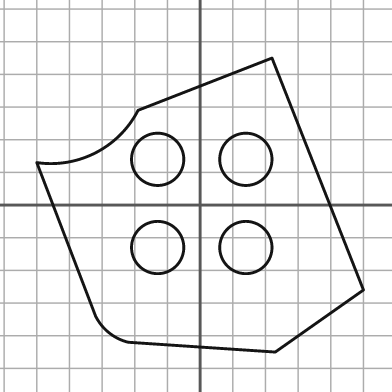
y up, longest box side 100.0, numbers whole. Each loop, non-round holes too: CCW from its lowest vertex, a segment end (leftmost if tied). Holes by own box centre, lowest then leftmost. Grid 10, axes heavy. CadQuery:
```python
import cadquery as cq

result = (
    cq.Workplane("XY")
    .moveTo(23.0, -45.0)
    .lineTo(50.0, -26.0)
    .lineTo(22.0, 45.0)
    .lineTo(-19.0, 29.0)
    .threePointArc((-32.0, 16.0), (-50.0, 13.0))
    .lineTo(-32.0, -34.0)
    .threePointArc((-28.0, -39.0), (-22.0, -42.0))
    .close()
    .moveTo(-13.0, -13.0)
    .circle(8.0)
    .moveTo(14.0, -13.0)
    .circle(8.0)
    .moveTo(-13.0, 14.0)
    .circle(8.0)
    .moveTo(14.0, 14.0)
    .circle(8.0)
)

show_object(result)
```